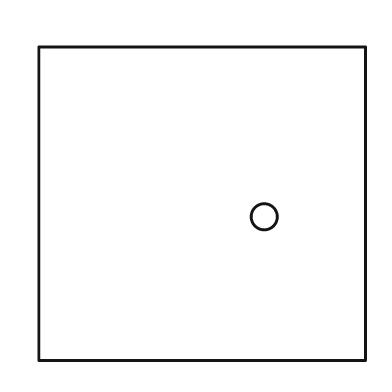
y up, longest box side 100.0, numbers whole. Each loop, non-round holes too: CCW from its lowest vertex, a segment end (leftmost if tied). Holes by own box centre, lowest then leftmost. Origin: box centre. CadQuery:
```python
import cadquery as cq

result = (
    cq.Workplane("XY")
    .moveTo(-50.0, -48.0)
    .lineTo(50.0, -48.0)
    .lineTo(50.0, 48.0)
    .lineTo(-50.0, 48.0)
    .close()
    .moveTo(19.0, -4.0)
    .circle(4.0)
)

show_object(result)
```